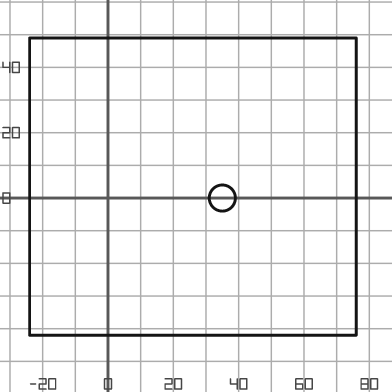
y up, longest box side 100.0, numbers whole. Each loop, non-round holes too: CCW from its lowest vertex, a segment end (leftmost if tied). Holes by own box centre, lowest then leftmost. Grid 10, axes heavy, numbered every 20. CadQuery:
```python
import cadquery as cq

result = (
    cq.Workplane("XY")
    .moveTo(-24.0, -42.0)
    .lineTo(76.0, -42.0)
    .lineTo(76.0, 49.0)
    .lineTo(-24.0, 49.0)
    .close()
    .moveTo(35.0, 0.0)
    .circle(4.0)
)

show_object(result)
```